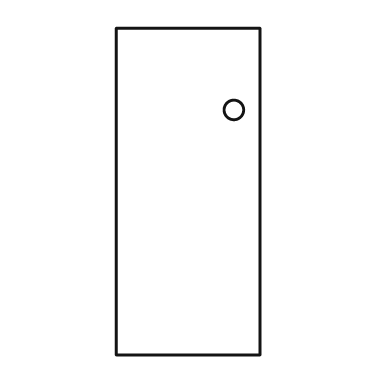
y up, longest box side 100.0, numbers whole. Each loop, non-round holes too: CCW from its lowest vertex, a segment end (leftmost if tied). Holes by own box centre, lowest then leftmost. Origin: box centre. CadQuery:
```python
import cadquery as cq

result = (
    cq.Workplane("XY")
    .moveTo(-22.0, -50.0)
    .lineTo(22.0, -50.0)
    .lineTo(22.0, 50.0)
    .lineTo(-22.0, 50.0)
    .close()
    .moveTo(14.0, 25.0)
    .circle(3.0)
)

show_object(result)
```